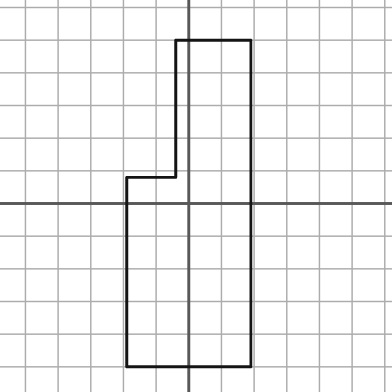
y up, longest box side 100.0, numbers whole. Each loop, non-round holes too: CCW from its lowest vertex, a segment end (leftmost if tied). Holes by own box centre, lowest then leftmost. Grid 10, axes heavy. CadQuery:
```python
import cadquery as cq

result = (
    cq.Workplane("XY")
    .moveTo(-19.0, -50.0)
    .lineTo(19.0, -50.0)
    .lineTo(19.0, 50.0)
    .lineTo(-4.0, 50.0)
    .lineTo(-4.0, 8.0)
    .lineTo(-19.0, 8.0)
    .close()
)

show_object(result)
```